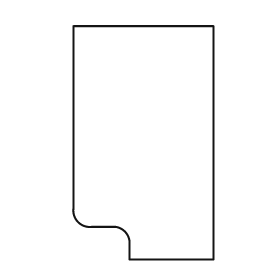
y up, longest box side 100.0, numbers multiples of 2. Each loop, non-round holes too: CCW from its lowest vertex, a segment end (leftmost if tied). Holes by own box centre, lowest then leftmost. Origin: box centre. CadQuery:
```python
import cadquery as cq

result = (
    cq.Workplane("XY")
    .moveTo(-6.0, -50.0)
    .lineTo(30.0, -50.0)
    .lineTo(30.0, 50.0)
    .lineTo(-30.0, 50.0)
    .lineTo(-30.0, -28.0)
    .threePointArc((-28.0, -34.0), (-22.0, -36.0))
    .lineTo(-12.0, -36.0)
    .threePointArc((-8.0, -38.0), (-6.0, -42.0))
    .close()
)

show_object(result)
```